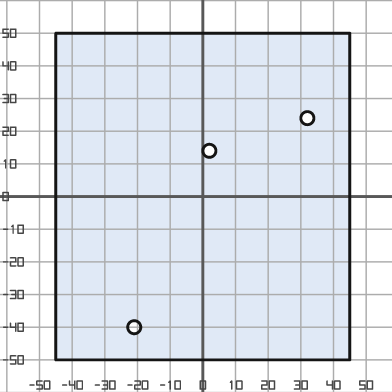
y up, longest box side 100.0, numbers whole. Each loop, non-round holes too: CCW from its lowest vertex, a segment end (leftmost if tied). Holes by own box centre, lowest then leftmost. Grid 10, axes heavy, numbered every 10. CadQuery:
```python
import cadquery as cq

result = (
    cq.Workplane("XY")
    .moveTo(-45.0, -50.0)
    .lineTo(45.0, -50.0)
    .lineTo(45.0, 50.0)
    .lineTo(-45.0, 50.0)
    .close()
    .moveTo(-21.0, -40.0)
    .circle(2.0)
    .moveTo(2.0, 14.0)
    .circle(2.0)
    .moveTo(32.0, 24.0)
    .circle(2.0)
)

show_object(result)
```